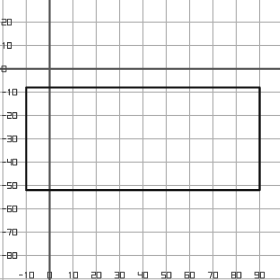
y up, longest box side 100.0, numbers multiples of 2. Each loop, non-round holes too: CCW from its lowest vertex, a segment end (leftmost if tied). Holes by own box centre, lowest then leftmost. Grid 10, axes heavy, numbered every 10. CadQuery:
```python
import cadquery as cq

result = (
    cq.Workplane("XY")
    .moveTo(-10.0, -52.0)
    .lineTo(90.0, -52.0)
    .lineTo(90.0, -8.0)
    .lineTo(-10.0, -8.0)
    .close()
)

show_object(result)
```